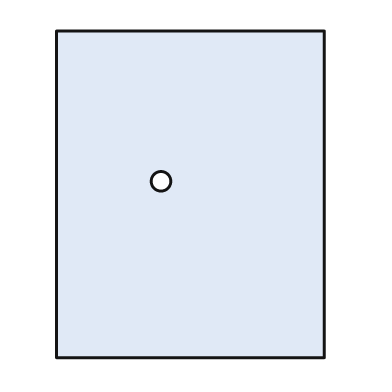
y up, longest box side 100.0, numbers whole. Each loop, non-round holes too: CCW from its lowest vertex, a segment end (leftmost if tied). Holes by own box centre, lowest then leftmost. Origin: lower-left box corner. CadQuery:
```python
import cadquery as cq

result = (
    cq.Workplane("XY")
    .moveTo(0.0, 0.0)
    .lineTo(82.0, 0.0)
    .lineTo(82.0, 100.0)
    .lineTo(0.0, 100.0)
    .close()
    .moveTo(32.0, 54.0)
    .circle(3.0)
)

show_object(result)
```